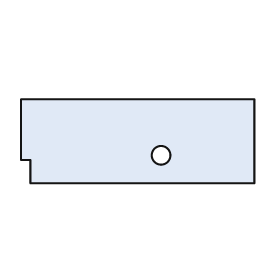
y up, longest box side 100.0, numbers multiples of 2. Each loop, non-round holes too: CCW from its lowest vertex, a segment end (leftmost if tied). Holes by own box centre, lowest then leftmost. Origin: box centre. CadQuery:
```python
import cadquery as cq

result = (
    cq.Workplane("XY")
    .moveTo(-46.0, -18.0)
    .lineTo(50.0, -18.0)
    .lineTo(50.0, 18.0)
    .lineTo(-50.0, 18.0)
    .lineTo(-50.0, -8.0)
    .lineTo(-46.0, -8.0)
    .close()
    .moveTo(10.0, -6.0)
    .circle(4.0)
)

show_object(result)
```